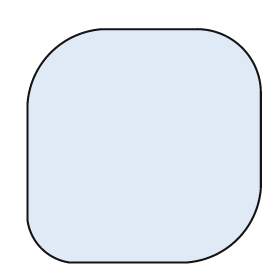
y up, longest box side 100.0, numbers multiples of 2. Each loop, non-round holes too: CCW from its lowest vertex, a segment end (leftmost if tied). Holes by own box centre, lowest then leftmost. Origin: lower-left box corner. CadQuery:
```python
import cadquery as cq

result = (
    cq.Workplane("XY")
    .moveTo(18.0, 0.0)
    .lineTo(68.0, 0.0)
    .threePointArc((90.0, 10.0), (100.0, 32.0))
    .lineTo(100.0, 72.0)
    .threePointArc((92.0, 92.0), (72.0, 100.0))
    .lineTo(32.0, 100.0)
    .threePointArc((10.0, 90.0), (0.0, 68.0))
    .lineTo(0.0, 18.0)
    .threePointArc((6.0, 6.0), (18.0, 0.0))
    .close()
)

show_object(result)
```